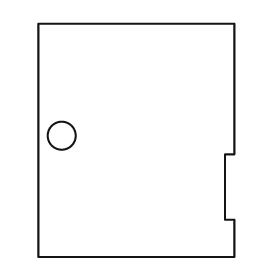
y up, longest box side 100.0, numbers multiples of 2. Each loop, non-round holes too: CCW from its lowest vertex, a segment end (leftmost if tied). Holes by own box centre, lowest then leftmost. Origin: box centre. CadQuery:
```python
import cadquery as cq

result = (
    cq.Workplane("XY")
    .moveTo(-42.0, -50.0)
    .lineTo(42.0, -50.0)
    .lineTo(42.0, -34.0)
    .lineTo(38.0, -34.0)
    .lineTo(38.0, -6.0)
    .lineTo(42.0, -6.0)
    .lineTo(42.0, 50.0)
    .lineTo(-42.0, 50.0)
    .close()
    .moveTo(-32.0, 2.0)
    .circle(6.0)
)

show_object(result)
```